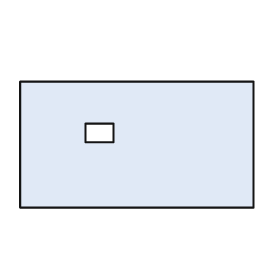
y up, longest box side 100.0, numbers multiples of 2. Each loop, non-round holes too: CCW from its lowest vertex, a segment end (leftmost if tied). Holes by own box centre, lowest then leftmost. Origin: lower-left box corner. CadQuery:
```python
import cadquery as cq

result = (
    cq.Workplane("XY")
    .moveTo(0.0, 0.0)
    .lineTo(100.0, 0.0)
    .lineTo(100.0, 54.0)
    .lineTo(0.0, 54.0)
    .close()
    .moveTo(28.0, 28.0)
    .lineTo(40.0, 28.0)
    .lineTo(40.0, 36.0)
    .lineTo(28.0, 36.0)
    .close()
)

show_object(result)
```